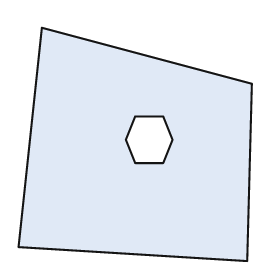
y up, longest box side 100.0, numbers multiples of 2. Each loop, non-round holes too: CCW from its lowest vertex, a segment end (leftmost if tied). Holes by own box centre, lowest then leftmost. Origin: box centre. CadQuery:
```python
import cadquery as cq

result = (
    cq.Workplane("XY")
    .moveTo(48.0, -50.0)
    .lineTo(50.0, 26.0)
    .lineTo(-40.0, 50.0)
    .lineTo(-50.0, -44.0)
    .close()
    .moveTo(0.0, -8.0)
    .lineTo(12.0, -8.0)
    .lineTo(16.0, 2.0)
    .lineTo(12.0, 12.0)
    .lineTo(0.0, 12.0)
    .lineTo(-4.0, 2.0)
    .close()
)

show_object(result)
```